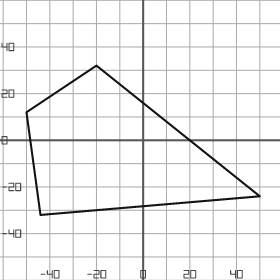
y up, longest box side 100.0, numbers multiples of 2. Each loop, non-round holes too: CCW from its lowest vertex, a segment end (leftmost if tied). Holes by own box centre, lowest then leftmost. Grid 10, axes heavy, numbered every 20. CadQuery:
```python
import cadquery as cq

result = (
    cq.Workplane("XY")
    .moveTo(-44.0, -32.0)
    .lineTo(50.0, -24.0)
    .lineTo(-20.0, 32.0)
    .lineTo(-50.0, 12.0)
    .close()
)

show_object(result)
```